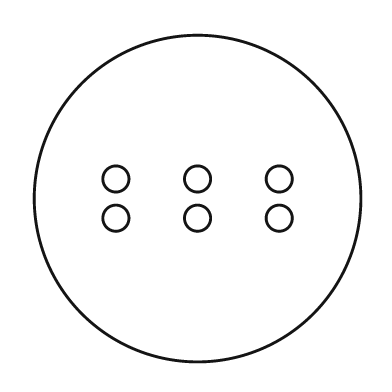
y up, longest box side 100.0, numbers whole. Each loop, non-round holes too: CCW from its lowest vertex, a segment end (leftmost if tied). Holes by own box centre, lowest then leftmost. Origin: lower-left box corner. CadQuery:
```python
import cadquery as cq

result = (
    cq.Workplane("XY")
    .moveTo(50.0, 50.0)
    .circle(50.0)
    .moveTo(25.0, 44.0)
    .circle(4.0)
    .moveTo(50.0, 44.0)
    .circle(4.0)
    .moveTo(75.0, 44.0)
    .circle(4.0)
    .moveTo(25.0, 56.0)
    .circle(4.0)
    .moveTo(50.0, 56.0)
    .circle(4.0)
    .moveTo(75.0, 56.0)
    .circle(4.0)
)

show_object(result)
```